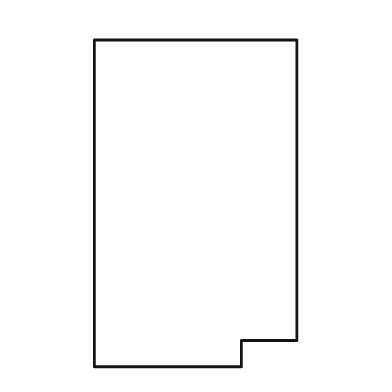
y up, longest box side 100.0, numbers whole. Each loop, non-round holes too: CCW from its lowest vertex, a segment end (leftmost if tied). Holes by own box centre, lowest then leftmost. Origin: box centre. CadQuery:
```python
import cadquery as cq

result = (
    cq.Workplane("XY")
    .moveTo(-31.0, -50.0)
    .lineTo(14.0, -50.0)
    .lineTo(14.0, -42.0)
    .lineTo(31.0, -42.0)
    .lineTo(31.0, 50.0)
    .lineTo(-31.0, 50.0)
    .close()
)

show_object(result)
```